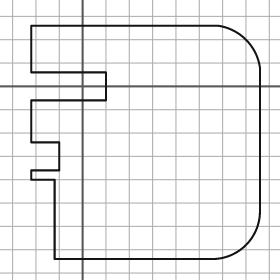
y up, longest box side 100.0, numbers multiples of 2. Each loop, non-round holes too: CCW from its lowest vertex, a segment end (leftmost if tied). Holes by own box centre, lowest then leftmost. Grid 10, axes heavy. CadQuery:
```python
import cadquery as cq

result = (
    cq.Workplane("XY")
    .moveTo(-12.0, -74.0)
    .lineTo(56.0, -74.0)
    .threePointArc((70.0, -68.0), (76.0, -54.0))
    .lineTo(76.0, 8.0)
    .threePointArc((70.0, 20.0), (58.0, 26.0))
    .lineTo(-22.0, 26.0)
    .lineTo(-22.0, 6.0)
    .lineTo(10.0, 6.0)
    .lineTo(10.0, -6.0)
    .lineTo(-22.0, -6.0)
    .lineTo(-22.0, -24.0)
    .lineTo(-10.0, -24.0)
    .lineTo(-10.0, -36.0)
    .lineTo(-22.0, -36.0)
    .lineTo(-22.0, -40.0)
    .lineTo(-12.0, -40.0)
    .close()
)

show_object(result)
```